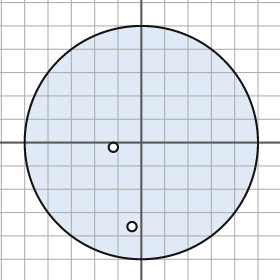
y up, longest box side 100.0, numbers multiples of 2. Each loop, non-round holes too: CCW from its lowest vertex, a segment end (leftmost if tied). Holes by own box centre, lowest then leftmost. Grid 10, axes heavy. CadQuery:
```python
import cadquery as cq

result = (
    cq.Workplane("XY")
    .moveTo(0.0, 0.0)
    .circle(50.0)
    .moveTo(-4.0, -36.0)
    .circle(2.0)
    .moveTo(-12.0, -2.0)
    .circle(2.0)
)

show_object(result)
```